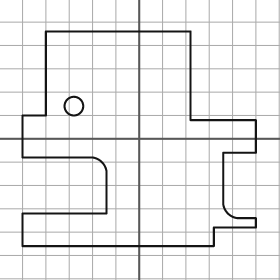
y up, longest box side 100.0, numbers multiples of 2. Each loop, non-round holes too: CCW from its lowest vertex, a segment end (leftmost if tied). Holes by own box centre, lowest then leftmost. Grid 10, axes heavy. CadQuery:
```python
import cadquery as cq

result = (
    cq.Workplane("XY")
    .moveTo(-50.0, -46.0)
    .lineTo(32.0, -46.0)
    .lineTo(32.0, -38.0)
    .lineTo(50.0, -38.0)
    .lineTo(50.0, -34.0)
    .lineTo(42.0, -34.0)
    .threePointArc((38.0, -32.0), (36.0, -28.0))
    .lineTo(36.0, -6.0)
    .lineTo(50.0, -6.0)
    .lineTo(50.0, 8.0)
    .lineTo(22.0, 8.0)
    .lineTo(22.0, 46.0)
    .lineTo(-40.0, 46.0)
    .lineTo(-40.0, 10.0)
    .lineTo(-50.0, 10.0)
    .lineTo(-50.0, -8.0)
    .lineTo(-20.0, -8.0)
    .threePointArc((-16.0, -10.0), (-14.0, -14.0))
    .lineTo(-14.0, -32.0)
    .lineTo(-50.0, -32.0)
    .close()
    .moveTo(-28.0, 14.0)
    .circle(4.0)
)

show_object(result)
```